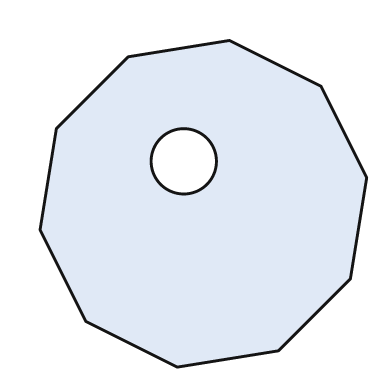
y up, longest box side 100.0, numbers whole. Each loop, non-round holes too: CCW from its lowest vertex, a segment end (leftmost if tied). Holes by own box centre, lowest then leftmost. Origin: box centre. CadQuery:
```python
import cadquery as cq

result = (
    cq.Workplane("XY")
    .moveTo(-8.0, -50.0)
    .lineTo(23.0, -45.0)
    .lineTo(45.0, -23.0)
    .lineTo(50.0, 8.0)
    .lineTo(36.0, 36.0)
    .lineTo(8.0, 50.0)
    .lineTo(-23.0, 45.0)
    .lineTo(-45.0, 23.0)
    .lineTo(-50.0, -8.0)
    .lineTo(-36.0, -36.0)
    .close()
    .moveTo(-6.0, 13.0)
    .circle(10.0)
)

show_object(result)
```